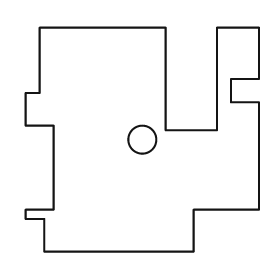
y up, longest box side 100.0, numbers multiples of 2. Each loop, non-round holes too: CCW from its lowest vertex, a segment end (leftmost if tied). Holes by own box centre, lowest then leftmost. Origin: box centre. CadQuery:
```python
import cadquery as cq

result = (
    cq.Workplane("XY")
    .moveTo(-42.0, -48.0)
    .lineTo(22.0, -48.0)
    .lineTo(22.0, -30.0)
    .lineTo(50.0, -30.0)
    .lineTo(50.0, 16.0)
    .lineTo(38.0, 16.0)
    .lineTo(38.0, 26.0)
    .lineTo(50.0, 26.0)
    .lineTo(50.0, 48.0)
    .lineTo(32.0, 48.0)
    .lineTo(32.0, 4.0)
    .lineTo(10.0, 4.0)
    .lineTo(10.0, 48.0)
    .lineTo(-44.0, 48.0)
    .lineTo(-44.0, 20.0)
    .lineTo(-50.0, 20.0)
    .lineTo(-50.0, 6.0)
    .lineTo(-38.0, 6.0)
    .lineTo(-38.0, -30.0)
    .lineTo(-50.0, -30.0)
    .lineTo(-50.0, -34.0)
    .lineTo(-42.0, -34.0)
    .close()
    .moveTo(0.0, 0.0)
    .circle(6.0)
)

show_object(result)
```